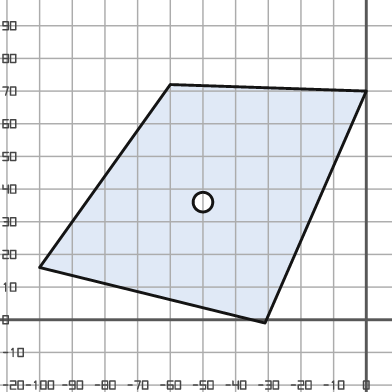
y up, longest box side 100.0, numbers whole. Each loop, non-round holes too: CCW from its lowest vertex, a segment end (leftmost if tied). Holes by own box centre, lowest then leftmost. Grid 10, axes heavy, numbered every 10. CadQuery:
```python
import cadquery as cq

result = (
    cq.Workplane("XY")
    .moveTo(-31.0, -1.0)
    .lineTo(0.0, 70.0)
    .lineTo(-60.0, 72.0)
    .lineTo(-100.0, 16.0)
    .close()
    .moveTo(-50.0, 36.0)
    .circle(3.0)
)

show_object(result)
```